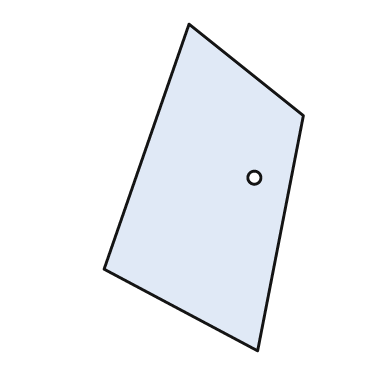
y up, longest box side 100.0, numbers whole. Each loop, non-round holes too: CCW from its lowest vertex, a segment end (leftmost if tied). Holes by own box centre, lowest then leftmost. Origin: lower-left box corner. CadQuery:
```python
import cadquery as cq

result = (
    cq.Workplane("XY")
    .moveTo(47.0, 0.0)
    .lineTo(61.0, 72.0)
    .lineTo(26.0, 100.0)
    .lineTo(0.0, 25.0)
    .close()
    .moveTo(46.0, 53.0)
    .circle(2.0)
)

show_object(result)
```